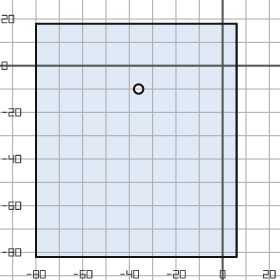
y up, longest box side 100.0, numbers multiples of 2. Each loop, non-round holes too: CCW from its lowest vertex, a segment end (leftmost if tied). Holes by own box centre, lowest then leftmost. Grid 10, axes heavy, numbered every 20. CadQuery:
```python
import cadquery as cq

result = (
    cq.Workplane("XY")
    .moveTo(-80.0, -82.0)
    .lineTo(6.0, -82.0)
    .lineTo(6.0, 18.0)
    .lineTo(-80.0, 18.0)
    .close()
    .moveTo(-36.0, -10.0)
    .circle(2.0)
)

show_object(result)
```